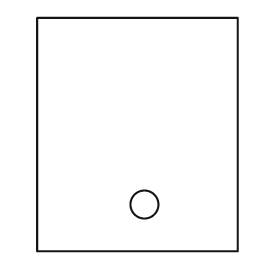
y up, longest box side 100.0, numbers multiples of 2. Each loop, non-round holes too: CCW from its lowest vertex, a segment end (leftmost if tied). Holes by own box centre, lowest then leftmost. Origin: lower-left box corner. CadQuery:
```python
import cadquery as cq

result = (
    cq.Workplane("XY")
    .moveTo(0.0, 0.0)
    .lineTo(86.0, 0.0)
    .lineTo(86.0, 100.0)
    .lineTo(0.0, 100.0)
    .close()
    .moveTo(46.0, 20.0)
    .circle(6.0)
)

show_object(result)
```